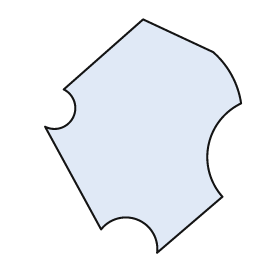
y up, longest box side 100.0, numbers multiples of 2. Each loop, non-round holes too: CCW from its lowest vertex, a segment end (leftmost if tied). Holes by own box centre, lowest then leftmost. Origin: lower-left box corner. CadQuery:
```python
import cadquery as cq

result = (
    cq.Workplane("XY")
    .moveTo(48.0, 0.0)
    .lineTo(76.0, 24.0)
    .threePointArc((70.0, 46.0), (84.0, 64.0))
    .threePointArc((80.0, 76.0), (72.0, 86.0))
    .lineTo(42.0, 100.0)
    .lineTo(8.0, 70.0)
    .threePointArc((12.0, 58.0), (0.0, 54.0))
    .lineTo(24.0, 10.0)
    .threePointArc((40.0, 14.0), (48.0, 0.0))
    .close()
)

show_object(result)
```